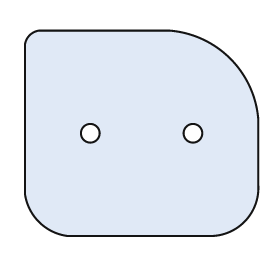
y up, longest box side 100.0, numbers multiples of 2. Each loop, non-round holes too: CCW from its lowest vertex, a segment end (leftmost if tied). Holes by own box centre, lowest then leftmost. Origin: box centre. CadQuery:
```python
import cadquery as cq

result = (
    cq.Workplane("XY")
    .moveTo(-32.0, -44.0)
    .lineTo(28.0, -44.0)
    .threePointArc((44.0, -38.0), (50.0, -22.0))
    .lineTo(50.0, 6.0)
    .threePointArc((38.0, 32.0), (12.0, 44.0))
    .lineTo(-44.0, 44.0)
    .threePointArc((-48.0, 42.0), (-50.0, 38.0))
    .lineTo(-50.0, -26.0)
    .threePointArc((-44.0, -38.0), (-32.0, -44.0))
    .close()
    .moveTo(-22.0, 0.0)
    .circle(4.0)
    .moveTo(22.0, 0.0)
    .circle(4.0)
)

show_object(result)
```